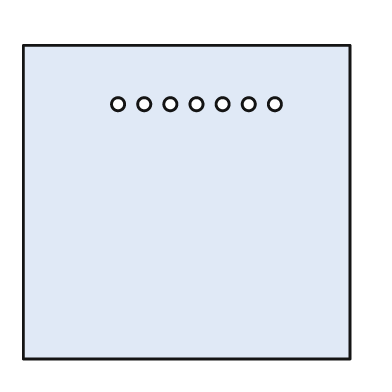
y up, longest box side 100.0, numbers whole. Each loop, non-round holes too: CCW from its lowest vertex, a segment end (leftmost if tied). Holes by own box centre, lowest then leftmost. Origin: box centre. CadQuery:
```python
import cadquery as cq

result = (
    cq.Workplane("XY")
    .moveTo(-50.0, -48.0)
    .lineTo(50.0, -48.0)
    .lineTo(50.0, 48.0)
    .lineTo(-50.0, 48.0)
    .close()
    .moveTo(-21.0, 30.0)
    .circle(2.0)
    .moveTo(-13.0, 30.0)
    .circle(2.0)
    .moveTo(-5.0, 30.0)
    .circle(2.0)
    .moveTo(3.0, 30.0)
    .circle(2.0)
    .moveTo(11.0, 30.0)
    .circle(2.0)
    .moveTo(19.0, 30.0)
    .circle(2.0)
    .moveTo(27.0, 30.0)
    .circle(2.0)
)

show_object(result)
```